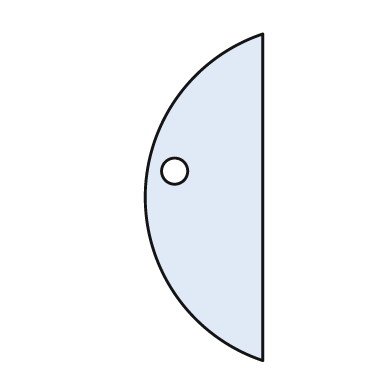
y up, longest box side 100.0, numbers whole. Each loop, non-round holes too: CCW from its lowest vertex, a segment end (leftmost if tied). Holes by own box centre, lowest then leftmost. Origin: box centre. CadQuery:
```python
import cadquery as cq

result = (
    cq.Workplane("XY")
    .moveTo(18.0, -50.0)
    .lineTo(18.0, 50.0)
    .threePointArc((-18.0, 0.0), (18.0, -50.0))
    .close()
    .moveTo(-9.0, 8.0)
    .circle(4.0)
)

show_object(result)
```